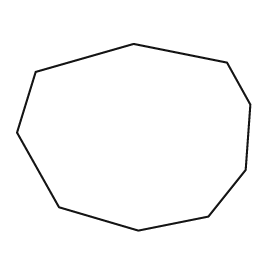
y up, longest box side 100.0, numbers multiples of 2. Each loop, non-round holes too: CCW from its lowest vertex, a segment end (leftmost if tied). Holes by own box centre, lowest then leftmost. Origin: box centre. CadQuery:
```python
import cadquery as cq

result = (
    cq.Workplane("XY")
    .moveTo(2.0, -40.0)
    .lineTo(32.0, -34.0)
    .lineTo(48.0, -14.0)
    .lineTo(50.0, 14.0)
    .lineTo(40.0, 32.0)
    .lineTo(0.0, 40.0)
    .lineTo(-42.0, 28.0)
    .lineTo(-50.0, 2.0)
    .lineTo(-32.0, -30.0)
    .close()
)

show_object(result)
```